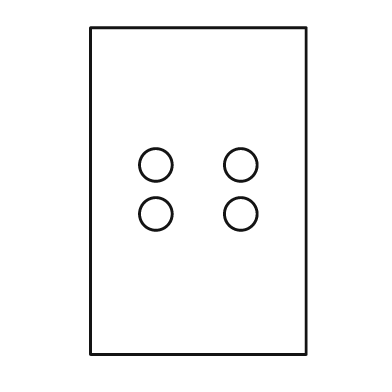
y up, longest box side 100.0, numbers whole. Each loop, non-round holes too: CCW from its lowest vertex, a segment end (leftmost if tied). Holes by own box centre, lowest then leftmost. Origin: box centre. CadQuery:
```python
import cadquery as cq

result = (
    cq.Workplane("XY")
    .moveTo(-33.0, -50.0)
    .lineTo(33.0, -50.0)
    .lineTo(33.0, 50.0)
    .lineTo(-33.0, 50.0)
    .close()
    .moveTo(-13.0, -7.0)
    .circle(5.0)
    .moveTo(13.0, -7.0)
    .circle(5.0)
    .moveTo(-13.0, 8.0)
    .circle(5.0)
    .moveTo(13.0, 8.0)
    .circle(5.0)
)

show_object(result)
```